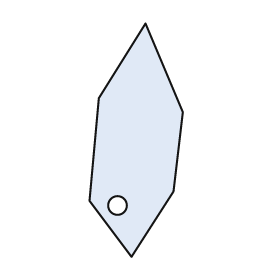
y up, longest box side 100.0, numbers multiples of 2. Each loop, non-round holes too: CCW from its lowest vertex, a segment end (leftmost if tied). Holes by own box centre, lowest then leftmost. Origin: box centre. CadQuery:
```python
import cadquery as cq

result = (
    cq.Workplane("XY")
    .moveTo(-2.0, -50.0)
    .lineTo(16.0, -22.0)
    .lineTo(20.0, 12.0)
    .lineTo(4.0, 50.0)
    .lineTo(-16.0, 18.0)
    .lineTo(-20.0, -26.0)
    .close()
    .moveTo(-8.0, -28.0)
    .circle(4.0)
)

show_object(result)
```